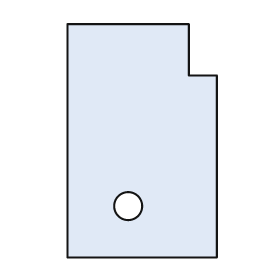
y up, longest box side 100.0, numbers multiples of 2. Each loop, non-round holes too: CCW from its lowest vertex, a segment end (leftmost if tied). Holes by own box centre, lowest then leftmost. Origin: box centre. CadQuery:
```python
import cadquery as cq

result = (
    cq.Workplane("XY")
    .moveTo(-32.0, -50.0)
    .lineTo(32.0, -50.0)
    .lineTo(32.0, 28.0)
    .lineTo(20.0, 28.0)
    .lineTo(20.0, 50.0)
    .lineTo(-32.0, 50.0)
    .close()
    .moveTo(-6.0, -28.0)
    .circle(6.0)
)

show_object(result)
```